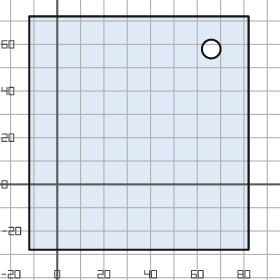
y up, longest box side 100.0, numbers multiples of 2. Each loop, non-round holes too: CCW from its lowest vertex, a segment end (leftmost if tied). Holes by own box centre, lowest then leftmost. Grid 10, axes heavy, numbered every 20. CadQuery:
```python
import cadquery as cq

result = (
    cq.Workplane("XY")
    .moveTo(-12.0, -28.0)
    .lineTo(82.0, -28.0)
    .lineTo(82.0, 72.0)
    .lineTo(-12.0, 72.0)
    .close()
    .moveTo(66.0, 58.0)
    .circle(4.0)
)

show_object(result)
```